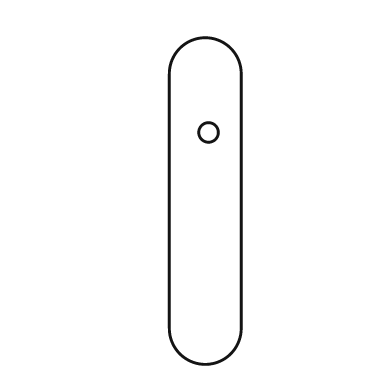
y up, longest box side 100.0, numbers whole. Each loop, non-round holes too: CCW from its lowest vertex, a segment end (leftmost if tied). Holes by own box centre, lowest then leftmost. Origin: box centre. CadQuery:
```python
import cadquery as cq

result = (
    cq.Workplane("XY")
    .moveTo(-11.0, -39.0)
    .threePointArc((0.0, -50.0), (11.0, -39.0))
    .lineTo(11.0, 39.0)
    .threePointArc((0.0, 50.0), (-11.0, 39.0))
    .close()
    .moveTo(1.0, 21.0)
    .circle(3.0)
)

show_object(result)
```